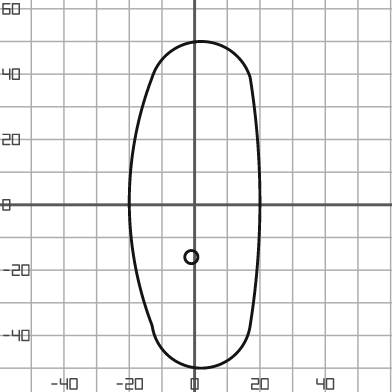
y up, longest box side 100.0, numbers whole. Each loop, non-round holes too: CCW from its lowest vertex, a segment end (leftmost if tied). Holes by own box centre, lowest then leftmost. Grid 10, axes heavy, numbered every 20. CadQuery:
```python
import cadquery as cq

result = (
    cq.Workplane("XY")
    .moveTo(-13.0, -37.0)
    .threePointArc((2.0, -50.0), (17.0, -37.0))
    .threePointArc((20.0, 1.0), (17.0, 39.0))
    .threePointArc((2.0, 50.0), (-13.0, 39.0))
    .threePointArc((-20.0, 1.0), (-13.0, -37.0))
    .close()
    .moveTo(-1.0, -16.0)
    .circle(2.0)
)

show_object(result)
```